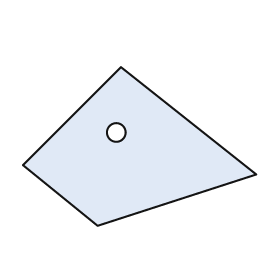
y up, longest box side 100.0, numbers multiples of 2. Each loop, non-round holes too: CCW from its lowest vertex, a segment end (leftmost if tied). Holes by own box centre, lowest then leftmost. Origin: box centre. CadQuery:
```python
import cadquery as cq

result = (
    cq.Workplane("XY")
    .moveTo(-18.0, -34.0)
    .lineTo(50.0, -12.0)
    .lineTo(-8.0, 34.0)
    .lineTo(-50.0, -8.0)
    .close()
    .moveTo(-10.0, 6.0)
    .circle(4.0)
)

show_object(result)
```